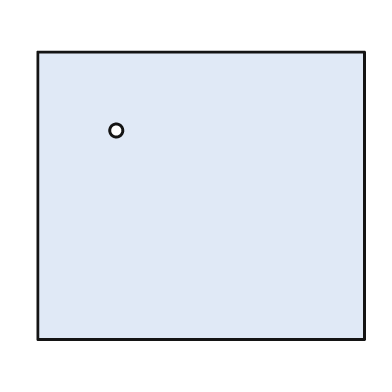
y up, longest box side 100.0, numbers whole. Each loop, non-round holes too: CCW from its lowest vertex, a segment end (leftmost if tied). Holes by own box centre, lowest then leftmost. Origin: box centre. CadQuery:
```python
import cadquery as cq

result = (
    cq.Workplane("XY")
    .moveTo(-50.0, -44.0)
    .lineTo(50.0, -44.0)
    .lineTo(50.0, 44.0)
    .lineTo(-50.0, 44.0)
    .close()
    .moveTo(-26.0, 20.0)
    .circle(2.0)
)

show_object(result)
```